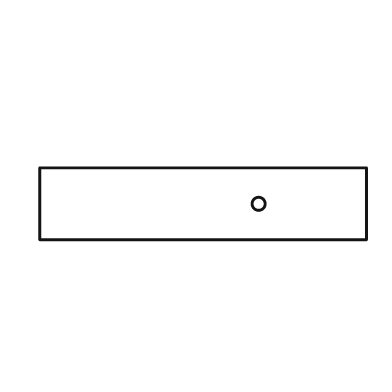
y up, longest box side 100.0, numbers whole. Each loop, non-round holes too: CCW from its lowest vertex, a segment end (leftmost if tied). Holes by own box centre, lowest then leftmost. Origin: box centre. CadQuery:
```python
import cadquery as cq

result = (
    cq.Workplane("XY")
    .moveTo(-50.0, -11.0)
    .lineTo(50.0, -11.0)
    .lineTo(50.0, 11.0)
    .lineTo(-50.0, 11.0)
    .close()
    .moveTo(17.0, 0.0)
    .circle(2.0)
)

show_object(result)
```